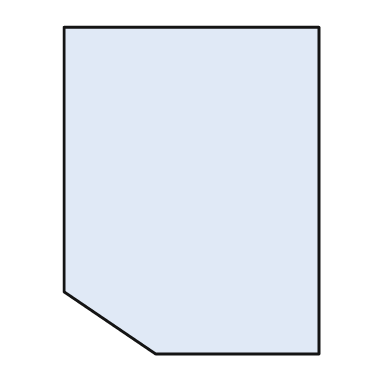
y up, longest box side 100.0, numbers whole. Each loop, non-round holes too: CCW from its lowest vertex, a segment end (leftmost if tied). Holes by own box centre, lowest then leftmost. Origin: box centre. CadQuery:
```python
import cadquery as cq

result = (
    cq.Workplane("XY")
    .moveTo(-11.0, -50.0)
    .lineTo(39.0, -50.0)
    .lineTo(39.0, 50.0)
    .lineTo(-39.0, 50.0)
    .lineTo(-39.0, -31.0)
    .close()
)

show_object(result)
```